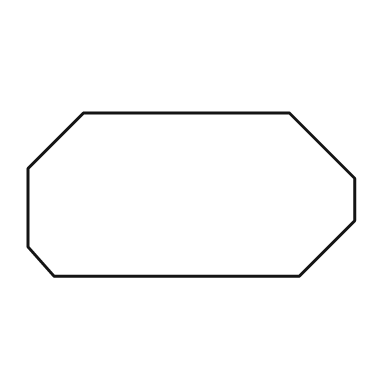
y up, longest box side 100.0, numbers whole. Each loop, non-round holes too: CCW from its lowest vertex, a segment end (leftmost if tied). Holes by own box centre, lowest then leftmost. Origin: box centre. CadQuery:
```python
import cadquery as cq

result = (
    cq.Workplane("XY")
    .moveTo(-42.0, -25.0)
    .lineTo(33.0, -25.0)
    .lineTo(50.0, -8.0)
    .lineTo(50.0, 5.0)
    .lineTo(30.0, 25.0)
    .lineTo(-33.0, 25.0)
    .lineTo(-50.0, 8.0)
    .lineTo(-50.0, -16.0)
    .close()
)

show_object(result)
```